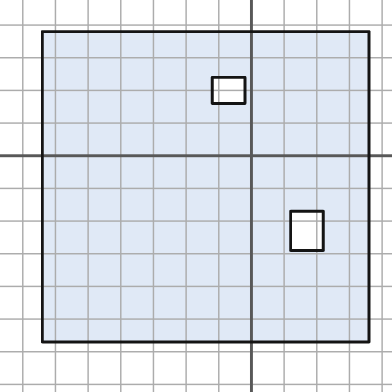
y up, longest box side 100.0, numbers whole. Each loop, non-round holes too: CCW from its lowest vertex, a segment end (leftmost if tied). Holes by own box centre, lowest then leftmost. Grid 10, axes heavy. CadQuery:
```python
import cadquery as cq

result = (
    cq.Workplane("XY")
    .moveTo(-64.0, -57.0)
    .lineTo(36.0, -57.0)
    .lineTo(36.0, 38.0)
    .lineTo(-64.0, 38.0)
    .close()
    .moveTo(12.0, -29.0)
    .lineTo(22.0, -29.0)
    .lineTo(22.0, -17.0)
    .lineTo(12.0, -17.0)
    .close()
    .moveTo(-12.0, 16.0)
    .lineTo(-2.0, 16.0)
    .lineTo(-2.0, 24.0)
    .lineTo(-12.0, 24.0)
    .close()
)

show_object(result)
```